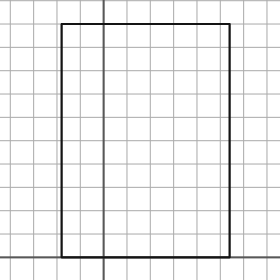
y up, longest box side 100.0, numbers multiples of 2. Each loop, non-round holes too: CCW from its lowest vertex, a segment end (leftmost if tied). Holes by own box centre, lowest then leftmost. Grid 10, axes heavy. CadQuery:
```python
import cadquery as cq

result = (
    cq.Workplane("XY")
    .moveTo(-18.0, 0.0)
    .lineTo(54.0, 0.0)
    .lineTo(54.0, 100.0)
    .lineTo(-18.0, 100.0)
    .close()
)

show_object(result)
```